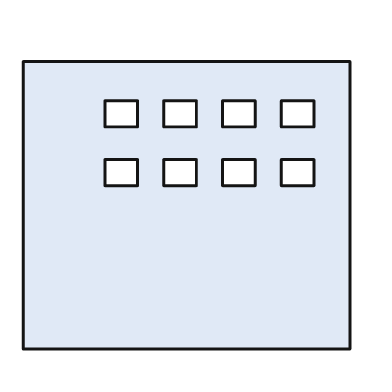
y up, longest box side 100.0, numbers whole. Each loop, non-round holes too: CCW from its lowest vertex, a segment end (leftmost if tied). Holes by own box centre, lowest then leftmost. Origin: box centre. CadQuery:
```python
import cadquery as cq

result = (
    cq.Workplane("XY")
    .moveTo(-50.0, -44.0)
    .lineTo(50.0, -44.0)
    .lineTo(50.0, 44.0)
    .lineTo(-50.0, 44.0)
    .close()
    .moveTo(-25.0, 6.0)
    .lineTo(-15.0, 6.0)
    .lineTo(-15.0, 14.0)
    .lineTo(-25.0, 14.0)
    .close()
    .moveTo(-7.0, 6.0)
    .lineTo(3.0, 6.0)
    .lineTo(3.0, 14.0)
    .lineTo(-7.0, 14.0)
    .close()
    .moveTo(11.0, 6.0)
    .lineTo(21.0, 6.0)
    .lineTo(21.0, 14.0)
    .lineTo(11.0, 14.0)
    .close()
    .moveTo(29.0, 6.0)
    .lineTo(39.0, 6.0)
    .lineTo(39.0, 14.0)
    .lineTo(29.0, 14.0)
    .close()
    .moveTo(-25.0, 24.0)
    .lineTo(-15.0, 24.0)
    .lineTo(-15.0, 32.0)
    .lineTo(-25.0, 32.0)
    .close()
    .moveTo(-7.0, 24.0)
    .lineTo(3.0, 24.0)
    .lineTo(3.0, 32.0)
    .lineTo(-7.0, 32.0)
    .close()
    .moveTo(11.0, 24.0)
    .lineTo(21.0, 24.0)
    .lineTo(21.0, 32.0)
    .lineTo(11.0, 32.0)
    .close()
    .moveTo(29.0, 24.0)
    .lineTo(39.0, 24.0)
    .lineTo(39.0, 32.0)
    .lineTo(29.0, 32.0)
    .close()
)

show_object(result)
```